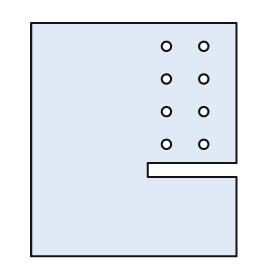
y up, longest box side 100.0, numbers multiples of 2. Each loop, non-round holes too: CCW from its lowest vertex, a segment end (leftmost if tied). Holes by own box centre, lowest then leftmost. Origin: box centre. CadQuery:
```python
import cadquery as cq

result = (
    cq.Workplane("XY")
    .moveTo(-44.0, -50.0)
    .lineTo(44.0, -50.0)
    .lineTo(44.0, -16.0)
    .lineTo(6.0, -16.0)
    .lineTo(6.0, -10.0)
    .lineTo(44.0, -10.0)
    .lineTo(44.0, 50.0)
    .lineTo(-44.0, 50.0)
    .close()
    .moveTo(14.0, -2.0)
    .circle(2.0)
    .moveTo(30.0, -2.0)
    .circle(2.0)
    .moveTo(14.0, 12.0)
    .circle(2.0)
    .moveTo(30.0, 12.0)
    .circle(2.0)
    .moveTo(14.0, 26.0)
    .circle(2.0)
    .moveTo(30.0, 26.0)
    .circle(2.0)
    .moveTo(14.0, 40.0)
    .circle(2.0)
    .moveTo(30.0, 40.0)
    .circle(2.0)
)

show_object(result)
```